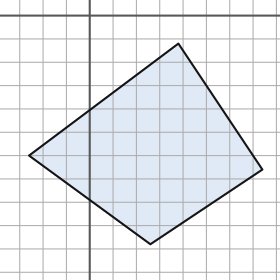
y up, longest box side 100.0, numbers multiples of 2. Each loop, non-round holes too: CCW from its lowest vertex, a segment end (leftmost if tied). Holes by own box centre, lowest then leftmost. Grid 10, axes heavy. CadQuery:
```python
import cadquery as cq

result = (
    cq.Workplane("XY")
    .moveTo(26.0, -98.0)
    .lineTo(74.0, -66.0)
    .lineTo(38.0, -12.0)
    .lineTo(-26.0, -60.0)
    .close()
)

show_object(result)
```